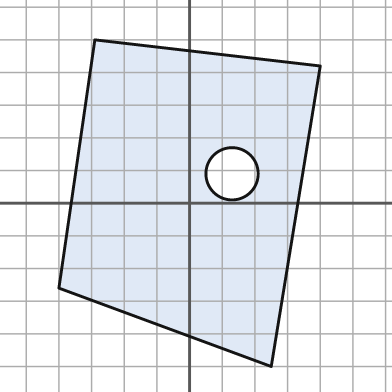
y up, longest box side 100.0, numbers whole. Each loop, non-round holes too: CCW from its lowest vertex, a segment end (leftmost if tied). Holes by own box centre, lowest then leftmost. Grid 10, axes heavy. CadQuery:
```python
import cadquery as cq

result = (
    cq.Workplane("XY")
    .moveTo(25.0, -50.0)
    .lineTo(40.0, 42.0)
    .lineTo(-29.0, 50.0)
    .lineTo(-40.0, -26.0)
    .close()
    .moveTo(13.0, 9.0)
    .circle(8.0)
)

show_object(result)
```